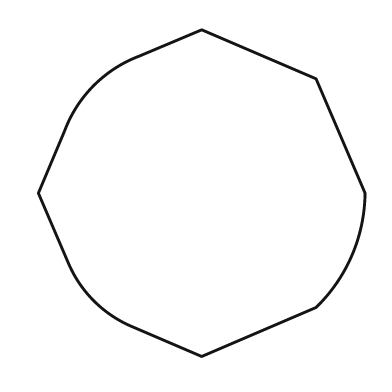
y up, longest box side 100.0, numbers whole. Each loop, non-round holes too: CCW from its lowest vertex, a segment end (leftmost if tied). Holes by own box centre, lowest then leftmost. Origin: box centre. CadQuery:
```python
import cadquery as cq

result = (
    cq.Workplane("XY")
    .moveTo(0.0, -50.0)
    .lineTo(35.0, -35.0)
    .threePointArc((46.0, -19.0), (50.0, 0.0))
    .lineTo(35.0, 35.0)
    .lineTo(0.0, 50.0)
    .lineTo(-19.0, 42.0)
    .threePointArc((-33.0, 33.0), (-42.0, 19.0))
    .lineTo(-50.0, 0.0)
    .lineTo(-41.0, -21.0)
    .threePointArc((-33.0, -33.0), (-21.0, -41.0))
    .close()
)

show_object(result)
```